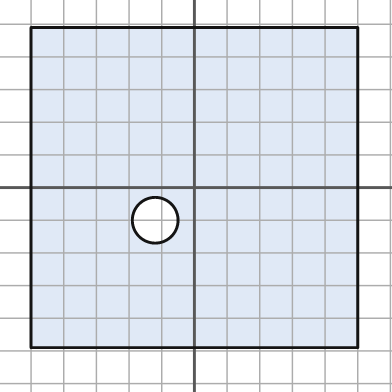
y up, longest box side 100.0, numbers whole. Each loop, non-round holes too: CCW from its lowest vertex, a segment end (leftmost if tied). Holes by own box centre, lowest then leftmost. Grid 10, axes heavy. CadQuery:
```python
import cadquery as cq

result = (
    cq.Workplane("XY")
    .moveTo(-50.0, -49.0)
    .lineTo(50.0, -49.0)
    .lineTo(50.0, 49.0)
    .lineTo(-50.0, 49.0)
    .close()
    .moveTo(-12.0, -10.0)
    .circle(7.0)
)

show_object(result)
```